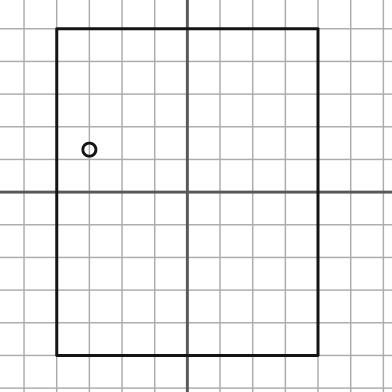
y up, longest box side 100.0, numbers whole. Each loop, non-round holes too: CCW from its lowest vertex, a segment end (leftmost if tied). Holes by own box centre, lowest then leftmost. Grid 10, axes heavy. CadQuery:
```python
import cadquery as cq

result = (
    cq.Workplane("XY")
    .moveTo(-40.0, -50.0)
    .lineTo(40.0, -50.0)
    .lineTo(40.0, 50.0)
    .lineTo(-40.0, 50.0)
    .close()
    .moveTo(-30.0, 13.0)
    .circle(2.0)
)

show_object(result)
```